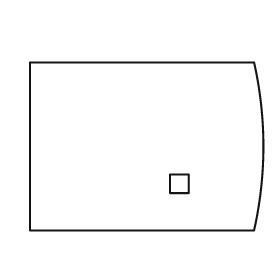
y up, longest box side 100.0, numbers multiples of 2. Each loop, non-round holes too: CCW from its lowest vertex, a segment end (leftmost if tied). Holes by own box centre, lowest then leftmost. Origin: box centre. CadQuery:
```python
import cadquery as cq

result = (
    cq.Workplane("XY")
    .moveTo(-50.0, -36.0)
    .lineTo(46.0, -36.0)
    .threePointArc((50.0, 0.0), (46.0, 36.0))
    .lineTo(-50.0, 36.0)
    .close()
    .moveTo(10.0, -20.0)
    .lineTo(18.0, -20.0)
    .lineTo(18.0, -12.0)
    .lineTo(10.0, -12.0)
    .close()
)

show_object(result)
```